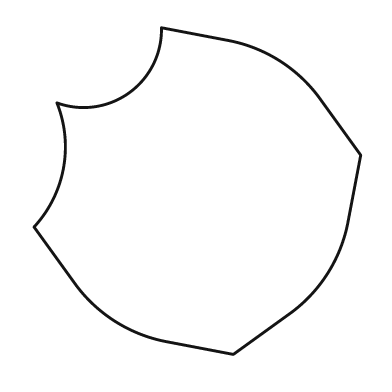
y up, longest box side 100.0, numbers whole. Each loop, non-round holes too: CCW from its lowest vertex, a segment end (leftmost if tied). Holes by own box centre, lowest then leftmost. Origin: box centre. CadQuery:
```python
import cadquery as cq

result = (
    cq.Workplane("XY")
    .moveTo(11.0, -50.0)
    .lineTo(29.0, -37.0)
    .threePointArc((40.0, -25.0), (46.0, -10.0))
    .lineTo(50.0, 11.0)
    .lineTo(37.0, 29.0)
    .threePointArc((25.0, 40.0), (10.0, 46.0))
    .lineTo(-11.0, 50.0)
    .threePointArc((-21.0, 30.0), (-43.0, 27.0))
    .threePointArc((-41.0, 7.0), (-50.0, -11.0))
    .lineTo(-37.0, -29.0)
    .threePointArc((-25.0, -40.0), (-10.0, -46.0))
    .close()
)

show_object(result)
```